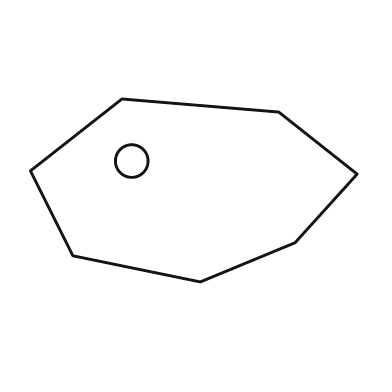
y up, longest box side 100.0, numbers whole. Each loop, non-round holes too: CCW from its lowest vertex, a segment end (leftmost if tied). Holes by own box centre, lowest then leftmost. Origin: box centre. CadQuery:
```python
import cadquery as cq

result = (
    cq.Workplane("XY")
    .moveTo(2.0, -28.0)
    .lineTo(31.0, -16.0)
    .lineTo(50.0, 5.0)
    .lineTo(26.0, 24.0)
    .lineTo(-22.0, 28.0)
    .lineTo(-50.0, 6.0)
    .lineTo(-37.0, -20.0)
    .close()
    .moveTo(-19.0, 9.0)
    .circle(5.0)
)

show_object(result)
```